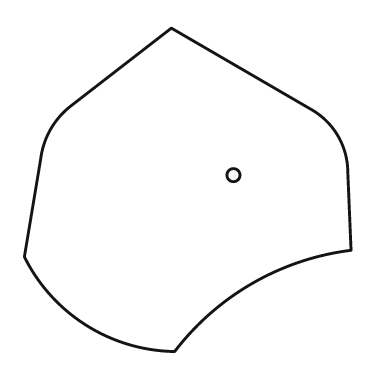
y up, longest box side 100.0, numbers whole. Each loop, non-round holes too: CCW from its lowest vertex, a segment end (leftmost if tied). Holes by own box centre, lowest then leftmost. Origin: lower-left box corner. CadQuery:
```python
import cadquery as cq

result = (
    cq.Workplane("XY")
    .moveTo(46.0, 0.0)
    .threePointArc((70.0, 21.0), (100.0, 31.0))
    .lineTo(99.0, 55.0)
    .threePointArc((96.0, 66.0), (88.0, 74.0))
    .lineTo(45.0, 99.0)
    .lineTo(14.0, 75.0)
    .threePointArc((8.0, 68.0), (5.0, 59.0))
    .lineTo(0.0, 29.0)
    .threePointArc((19.0, 8.0), (46.0, 0.0))
    .close()
    .moveTo(64.0, 54.0)
    .circle(2.0)
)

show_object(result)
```